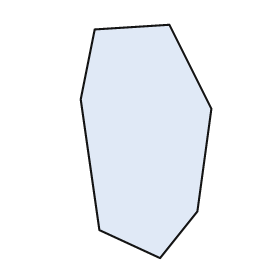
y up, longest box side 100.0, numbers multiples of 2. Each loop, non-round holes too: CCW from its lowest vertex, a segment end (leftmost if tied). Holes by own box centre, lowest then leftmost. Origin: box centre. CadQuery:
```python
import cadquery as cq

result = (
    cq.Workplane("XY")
    .moveTo(6.0, -50.0)
    .lineTo(22.0, -30.0)
    .lineTo(28.0, 14.0)
    .lineTo(10.0, 50.0)
    .lineTo(-22.0, 48.0)
    .lineTo(-28.0, 18.0)
    .lineTo(-20.0, -38.0)
    .close()
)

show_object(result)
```